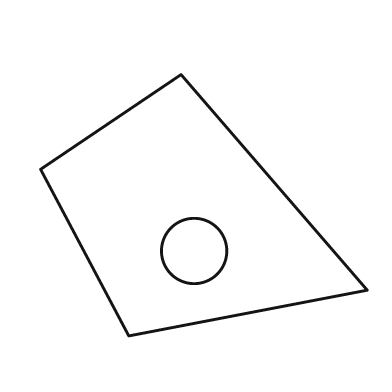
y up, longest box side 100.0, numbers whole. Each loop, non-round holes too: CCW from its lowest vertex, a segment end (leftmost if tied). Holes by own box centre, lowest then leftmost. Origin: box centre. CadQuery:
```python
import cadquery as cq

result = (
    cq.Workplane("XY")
    .moveTo(-23.0, -40.0)
    .lineTo(50.0, -26.0)
    .lineTo(-7.0, 40.0)
    .lineTo(-50.0, 11.0)
    .close()
    .moveTo(-3.0, -14.0)
    .circle(10.0)
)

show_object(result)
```